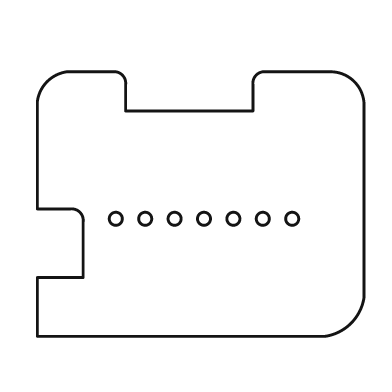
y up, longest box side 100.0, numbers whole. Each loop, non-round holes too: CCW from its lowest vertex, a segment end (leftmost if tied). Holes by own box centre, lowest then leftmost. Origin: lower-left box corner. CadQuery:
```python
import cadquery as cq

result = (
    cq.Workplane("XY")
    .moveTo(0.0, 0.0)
    .lineTo(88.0, 0.0)
    .threePointArc((96.0, 4.0), (100.0, 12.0))
    .lineTo(100.0, 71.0)
    .threePointArc((97.0, 78.0), (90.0, 81.0))
    .lineTo(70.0, 81.0)
    .threePointArc((67.0, 80.0), (66.0, 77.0))
    .lineTo(66.0, 69.0)
    .lineTo(27.0, 69.0)
    .lineTo(27.0, 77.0)
    .threePointArc((26.0, 80.0), (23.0, 81.0))
    .lineTo(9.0, 81.0)
    .threePointArc((3.0, 78.0), (0.0, 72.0))
    .lineTo(0.0, 39.0)
    .lineTo(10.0, 39.0)
    .threePointArc((13.0, 38.0), (14.0, 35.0))
    .lineTo(14.0, 18.0)
    .lineTo(0.0, 18.0)
    .close()
    .moveTo(24.0, 36.0)
    .circle(2.0)
    .moveTo(33.0, 36.0)
    .circle(2.0)
    .moveTo(42.0, 36.0)
    .circle(2.0)
    .moveTo(51.0, 36.0)
    .circle(2.0)
    .moveTo(60.0, 36.0)
    .circle(2.0)
    .moveTo(69.0, 36.0)
    .circle(2.0)
    .moveTo(78.0, 36.0)
    .circle(2.0)
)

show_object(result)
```